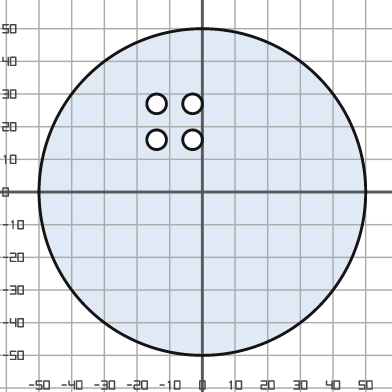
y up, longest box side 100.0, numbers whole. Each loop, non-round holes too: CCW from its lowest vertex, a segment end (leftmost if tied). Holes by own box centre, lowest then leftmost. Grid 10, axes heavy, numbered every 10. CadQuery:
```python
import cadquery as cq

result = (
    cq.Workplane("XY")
    .moveTo(0.0, 0.0)
    .circle(50.0)
    .moveTo(-14.0, 16.0)
    .circle(3.0)
    .moveTo(-3.0, 16.0)
    .circle(3.0)
    .moveTo(-14.0, 27.0)
    .circle(3.0)
    .moveTo(-3.0, 27.0)
    .circle(3.0)
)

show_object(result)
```